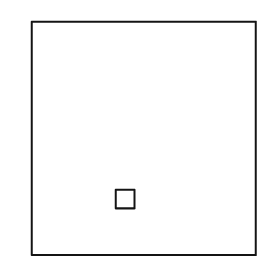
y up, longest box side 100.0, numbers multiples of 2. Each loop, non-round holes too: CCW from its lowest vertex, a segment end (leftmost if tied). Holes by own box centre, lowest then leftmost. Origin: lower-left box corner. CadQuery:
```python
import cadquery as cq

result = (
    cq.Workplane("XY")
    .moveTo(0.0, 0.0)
    .lineTo(96.0, 0.0)
    .lineTo(96.0, 100.0)
    .lineTo(0.0, 100.0)
    .close()
    .moveTo(36.0, 20.0)
    .lineTo(44.0, 20.0)
    .lineTo(44.0, 28.0)
    .lineTo(36.0, 28.0)
    .close()
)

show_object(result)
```